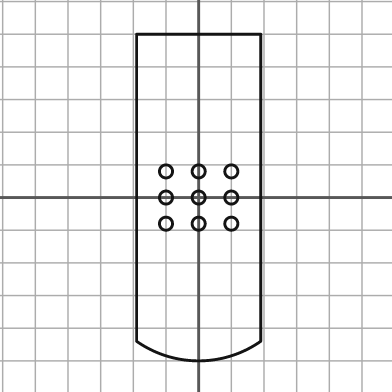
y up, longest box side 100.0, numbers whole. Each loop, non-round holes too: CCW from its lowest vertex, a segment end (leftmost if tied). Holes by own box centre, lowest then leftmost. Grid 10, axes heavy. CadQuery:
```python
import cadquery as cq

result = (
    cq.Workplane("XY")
    .moveTo(-19.0, -44.0)
    .threePointArc((0.0, -50.0), (19.0, -44.0))
    .lineTo(19.0, 50.0)
    .lineTo(-19.0, 50.0)
    .close()
    .moveTo(-10.0, -8.0)
    .circle(2.0)
    .moveTo(0.0, -8.0)
    .circle(2.0)
    .moveTo(10.0, -8.0)
    .circle(2.0)
    .moveTo(-10.0, 0.0)
    .circle(2.0)
    .moveTo(0.0, 0.0)
    .circle(2.0)
    .moveTo(10.0, 0.0)
    .circle(2.0)
    .moveTo(-10.0, 8.0)
    .circle(2.0)
    .moveTo(0.0, 8.0)
    .circle(2.0)
    .moveTo(10.0, 8.0)
    .circle(2.0)
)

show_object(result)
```